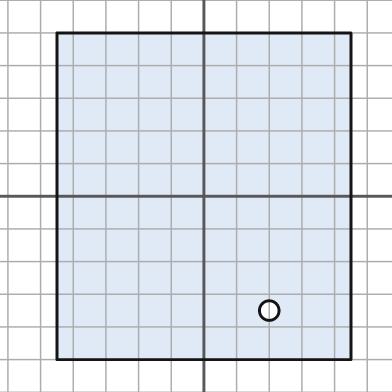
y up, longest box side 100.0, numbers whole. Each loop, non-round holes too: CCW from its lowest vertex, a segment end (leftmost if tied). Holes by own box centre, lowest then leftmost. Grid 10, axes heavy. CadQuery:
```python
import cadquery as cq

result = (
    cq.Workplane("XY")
    .moveTo(-45.0, -50.0)
    .lineTo(45.0, -50.0)
    .lineTo(45.0, 50.0)
    .lineTo(-45.0, 50.0)
    .close()
    .moveTo(20.0, -35.0)
    .circle(3.0)
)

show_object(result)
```